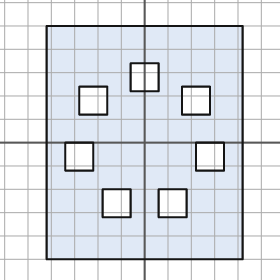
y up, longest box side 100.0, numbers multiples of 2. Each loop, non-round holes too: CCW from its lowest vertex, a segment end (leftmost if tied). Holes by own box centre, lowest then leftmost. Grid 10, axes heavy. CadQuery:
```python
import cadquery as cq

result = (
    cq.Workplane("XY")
    .moveTo(-42.0, -50.0)
    .lineTo(42.0, -50.0)
    .lineTo(42.0, 50.0)
    .lineTo(-42.0, 50.0)
    .close()
    .moveTo(-18.0, -32.0)
    .lineTo(-6.0, -32.0)
    .lineTo(-6.0, -20.0)
    .lineTo(-18.0, -20.0)
    .close()
    .moveTo(6.0, -32.0)
    .lineTo(18.0, -32.0)
    .lineTo(18.0, -20.0)
    .lineTo(6.0, -20.0)
    .close()
    .moveTo(-34.0, -12.0)
    .lineTo(-22.0, -12.0)
    .lineTo(-22.0, 0.0)
    .lineTo(-34.0, 0.0)
    .close()
    .moveTo(22.0, -12.0)
    .lineTo(34.0, -12.0)
    .lineTo(34.0, 0.0)
    .lineTo(22.0, 0.0)
    .close()
    .moveTo(-28.0, 12.0)
    .lineTo(-16.0, 12.0)
    .lineTo(-16.0, 24.0)
    .lineTo(-28.0, 24.0)
    .close()
    .moveTo(16.0, 12.0)
    .lineTo(28.0, 12.0)
    .lineTo(28.0, 24.0)
    .lineTo(16.0, 24.0)
    .close()
    .moveTo(-6.0, 22.0)
    .lineTo(6.0, 22.0)
    .lineTo(6.0, 34.0)
    .lineTo(-6.0, 34.0)
    .close()
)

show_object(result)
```